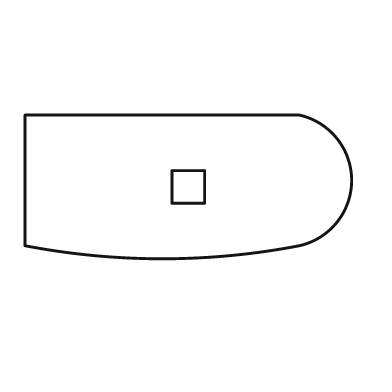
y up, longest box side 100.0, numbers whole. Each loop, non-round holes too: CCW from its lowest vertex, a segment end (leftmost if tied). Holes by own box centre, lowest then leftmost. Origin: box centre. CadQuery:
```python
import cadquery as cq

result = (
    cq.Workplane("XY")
    .moveTo(-50.0, -18.0)
    .threePointArc((-8.0, -22.0), (34.0, -18.0))
    .threePointArc((50.0, 2.0), (34.0, 22.0))
    .lineTo(-50.0, 22.0)
    .close()
    .moveTo(-5.0, -5.0)
    .lineTo(5.0, -5.0)
    .lineTo(5.0, 5.0)
    .lineTo(-5.0, 5.0)
    .close()
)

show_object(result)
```